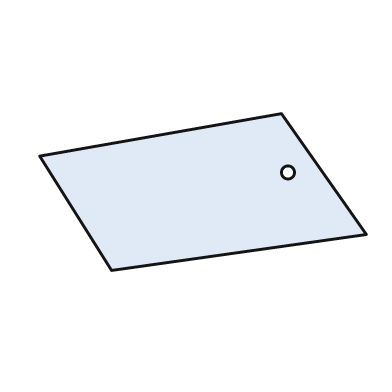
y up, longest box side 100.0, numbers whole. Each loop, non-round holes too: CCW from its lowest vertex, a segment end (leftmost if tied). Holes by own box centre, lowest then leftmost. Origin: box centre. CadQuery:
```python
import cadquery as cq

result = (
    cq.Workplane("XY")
    .moveTo(-28.0, -24.0)
    .lineTo(50.0, -13.0)
    .lineTo(24.0, 24.0)
    .lineTo(-50.0, 11.0)
    .close()
    .moveTo(26.0, 6.0)
    .circle(2.0)
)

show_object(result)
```